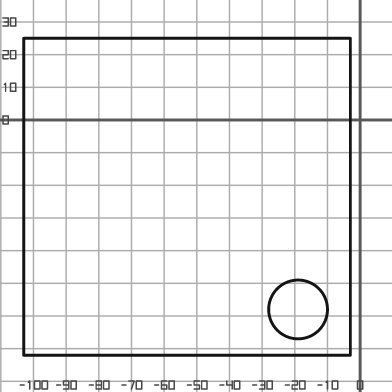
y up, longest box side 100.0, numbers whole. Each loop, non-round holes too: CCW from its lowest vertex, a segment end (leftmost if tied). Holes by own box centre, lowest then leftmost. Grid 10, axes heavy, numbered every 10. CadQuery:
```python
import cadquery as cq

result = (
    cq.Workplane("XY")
    .moveTo(-103.0, -72.0)
    .lineTo(-3.0, -72.0)
    .lineTo(-3.0, 25.0)
    .lineTo(-103.0, 25.0)
    .close()
    .moveTo(-19.0, -58.0)
    .circle(9.0)
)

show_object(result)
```